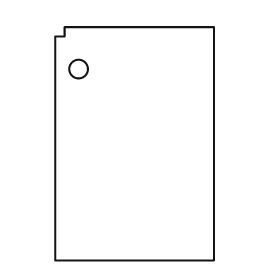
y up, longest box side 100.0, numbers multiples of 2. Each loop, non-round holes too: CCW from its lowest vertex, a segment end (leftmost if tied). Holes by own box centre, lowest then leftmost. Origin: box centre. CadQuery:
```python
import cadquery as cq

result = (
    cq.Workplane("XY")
    .moveTo(-34.0, -50.0)
    .lineTo(34.0, -50.0)
    .lineTo(34.0, 50.0)
    .lineTo(-30.0, 50.0)
    .lineTo(-30.0, 46.0)
    .lineTo(-34.0, 46.0)
    .close()
    .moveTo(-24.0, 32.0)
    .circle(4.0)
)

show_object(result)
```